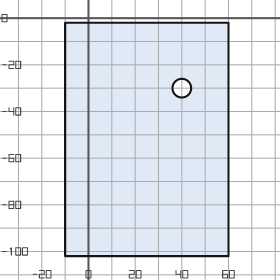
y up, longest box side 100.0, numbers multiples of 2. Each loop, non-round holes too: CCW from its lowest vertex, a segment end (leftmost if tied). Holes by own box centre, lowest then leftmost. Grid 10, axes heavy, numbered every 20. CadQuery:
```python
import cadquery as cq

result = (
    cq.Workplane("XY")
    .moveTo(-10.0, -102.0)
    .lineTo(60.0, -102.0)
    .lineTo(60.0, -2.0)
    .lineTo(-10.0, -2.0)
    .close()
    .moveTo(40.0, -30.0)
    .circle(4.0)
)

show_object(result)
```